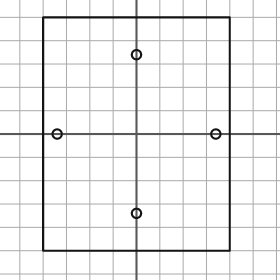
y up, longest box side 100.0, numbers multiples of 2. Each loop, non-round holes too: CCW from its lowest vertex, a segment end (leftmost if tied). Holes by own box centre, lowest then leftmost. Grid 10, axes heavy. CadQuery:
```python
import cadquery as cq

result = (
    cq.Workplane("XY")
    .moveTo(-40.0, -50.0)
    .lineTo(40.0, -50.0)
    .lineTo(40.0, 50.0)
    .lineTo(-40.0, 50.0)
    .close()
    .moveTo(0.0, -34.0)
    .circle(2.0)
    .moveTo(-34.0, 0.0)
    .circle(2.0)
    .moveTo(34.0, 0.0)
    .circle(2.0)
    .moveTo(0.0, 34.0)
    .circle(2.0)
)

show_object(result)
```